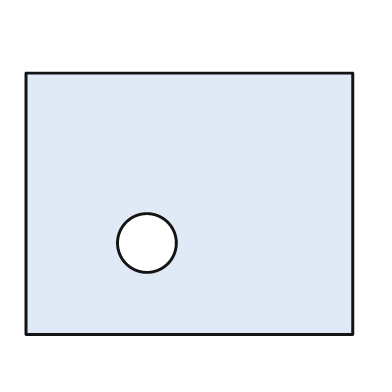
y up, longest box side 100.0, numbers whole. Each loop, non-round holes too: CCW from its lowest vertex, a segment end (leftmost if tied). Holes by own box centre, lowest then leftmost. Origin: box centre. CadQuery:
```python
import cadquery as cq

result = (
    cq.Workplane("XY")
    .moveTo(-50.0, -40.0)
    .lineTo(50.0, -40.0)
    .lineTo(50.0, 40.0)
    .lineTo(-50.0, 40.0)
    .close()
    .moveTo(-13.0, -12.0)
    .circle(9.0)
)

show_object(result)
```